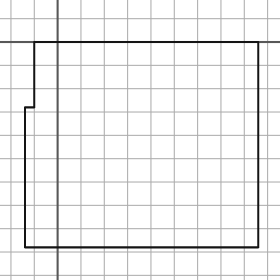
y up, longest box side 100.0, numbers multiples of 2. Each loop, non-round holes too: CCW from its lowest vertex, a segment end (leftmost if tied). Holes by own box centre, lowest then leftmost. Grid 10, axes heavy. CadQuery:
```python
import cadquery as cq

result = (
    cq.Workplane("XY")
    .moveTo(-14.0, -88.0)
    .lineTo(86.0, -88.0)
    .lineTo(86.0, 0.0)
    .lineTo(-10.0, 0.0)
    .lineTo(-10.0, -28.0)
    .lineTo(-14.0, -28.0)
    .close()
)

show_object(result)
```